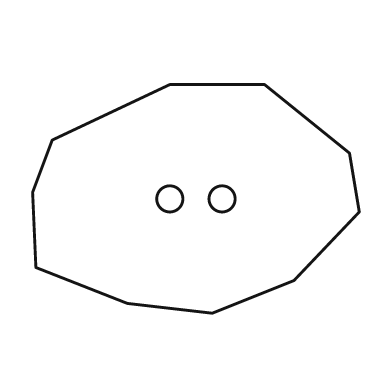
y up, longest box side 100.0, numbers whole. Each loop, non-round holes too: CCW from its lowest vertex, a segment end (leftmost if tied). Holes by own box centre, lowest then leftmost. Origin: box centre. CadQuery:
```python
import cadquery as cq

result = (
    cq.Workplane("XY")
    .moveTo(5.0, -35.0)
    .lineTo(30.0, -25.0)
    .lineTo(50.0, -4.0)
    .lineTo(47.0, 14.0)
    .lineTo(21.0, 35.0)
    .lineTo(-8.0, 35.0)
    .lineTo(-44.0, 18.0)
    .lineTo(-50.0, 2.0)
    .lineTo(-49.0, -21.0)
    .lineTo(-21.0, -32.0)
    .close()
    .moveTo(-8.0, 0.0)
    .circle(4.0)
    .moveTo(8.0, 0.0)
    .circle(4.0)
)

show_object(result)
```